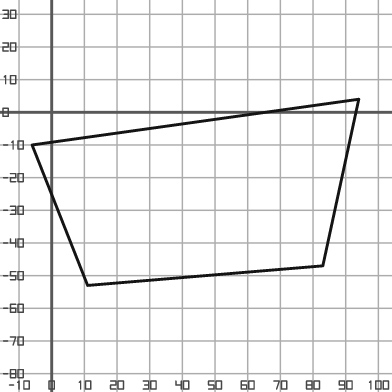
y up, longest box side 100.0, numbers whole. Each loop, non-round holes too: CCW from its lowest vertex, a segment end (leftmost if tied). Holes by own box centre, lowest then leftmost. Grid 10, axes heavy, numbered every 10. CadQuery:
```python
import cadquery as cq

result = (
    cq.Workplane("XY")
    .moveTo(11.0, -53.0)
    .lineTo(83.0, -47.0)
    .lineTo(94.0, 4.0)
    .lineTo(-6.0, -10.0)
    .close()
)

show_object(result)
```